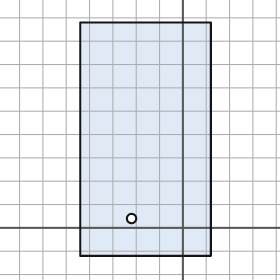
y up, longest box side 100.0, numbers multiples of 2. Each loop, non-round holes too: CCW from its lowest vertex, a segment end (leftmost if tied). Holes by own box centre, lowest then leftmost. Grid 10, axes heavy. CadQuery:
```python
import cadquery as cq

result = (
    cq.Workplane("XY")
    .moveTo(-44.0, -12.0)
    .lineTo(12.0, -12.0)
    .lineTo(12.0, 88.0)
    .lineTo(-44.0, 88.0)
    .close()
    .moveTo(-22.0, 4.0)
    .circle(2.0)
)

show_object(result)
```